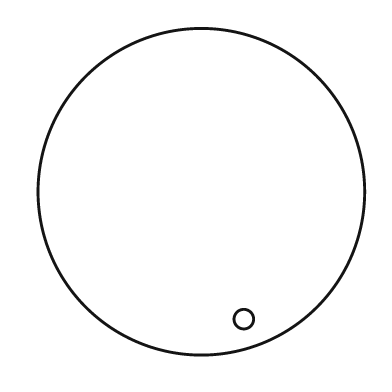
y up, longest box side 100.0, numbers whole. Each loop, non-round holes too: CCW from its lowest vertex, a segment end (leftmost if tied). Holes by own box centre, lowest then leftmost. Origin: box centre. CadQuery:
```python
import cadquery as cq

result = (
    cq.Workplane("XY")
    .moveTo(0.0, 0.0)
    .circle(50.0)
    .moveTo(13.0, -39.0)
    .circle(3.0)
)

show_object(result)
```